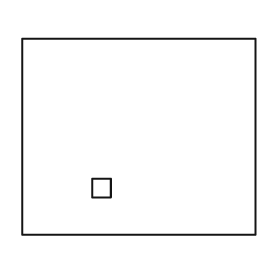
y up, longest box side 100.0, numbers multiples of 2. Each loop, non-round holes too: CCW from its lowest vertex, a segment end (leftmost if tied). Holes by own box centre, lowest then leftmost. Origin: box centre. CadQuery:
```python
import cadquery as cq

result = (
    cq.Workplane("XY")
    .moveTo(-50.0, -42.0)
    .lineTo(50.0, -42.0)
    .lineTo(50.0, 42.0)
    .lineTo(-50.0, 42.0)
    .close()
    .moveTo(-20.0, -26.0)
    .lineTo(-12.0, -26.0)
    .lineTo(-12.0, -18.0)
    .lineTo(-20.0, -18.0)
    .close()
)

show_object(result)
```